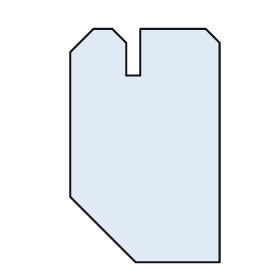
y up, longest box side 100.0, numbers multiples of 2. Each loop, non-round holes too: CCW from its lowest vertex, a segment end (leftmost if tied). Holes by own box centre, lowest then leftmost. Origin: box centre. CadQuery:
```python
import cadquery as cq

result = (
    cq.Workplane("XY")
    .moveTo(-4.0, -50.0)
    .lineTo(32.0, -50.0)
    .lineTo(32.0, 44.0)
    .lineTo(26.0, 50.0)
    .lineTo(-2.0, 50.0)
    .lineTo(-2.0, 30.0)
    .lineTo(-8.0, 30.0)
    .lineTo(-8.0, 44.0)
    .lineTo(-14.0, 50.0)
    .lineTo(-22.0, 50.0)
    .lineTo(-32.0, 40.0)
    .lineTo(-32.0, -22.0)
    .close()
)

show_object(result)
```